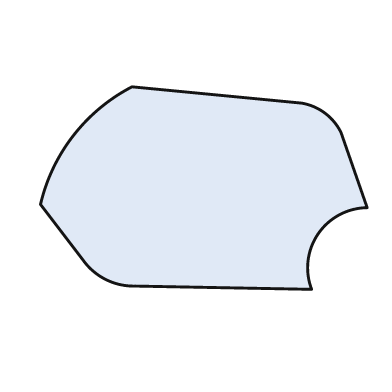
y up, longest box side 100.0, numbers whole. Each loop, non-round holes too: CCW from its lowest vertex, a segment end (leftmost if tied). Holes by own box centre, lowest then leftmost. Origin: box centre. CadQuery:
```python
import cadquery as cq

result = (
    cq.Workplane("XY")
    .moveTo(33.0, -31.0)
    .threePointArc((35.0, -14.0), (50.0, -6.0))
    .lineTo(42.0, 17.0)
    .threePointArc((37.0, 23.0), (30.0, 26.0))
    .lineTo(-22.0, 31.0)
    .threePointArc((-40.0, 16.0), (-50.0, -5.0))
    .lineTo(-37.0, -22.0)
    .threePointArc((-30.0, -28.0), (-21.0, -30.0))
    .close()
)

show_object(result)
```